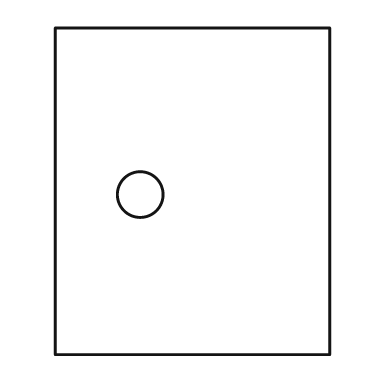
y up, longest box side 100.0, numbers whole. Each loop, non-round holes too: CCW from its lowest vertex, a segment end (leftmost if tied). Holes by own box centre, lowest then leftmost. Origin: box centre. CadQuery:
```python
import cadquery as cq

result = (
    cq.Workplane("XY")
    .moveTo(-42.0, -50.0)
    .lineTo(42.0, -50.0)
    .lineTo(42.0, 50.0)
    .lineTo(-42.0, 50.0)
    .close()
    .moveTo(-16.0, -1.0)
    .circle(7.0)
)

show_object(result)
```